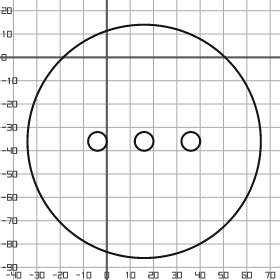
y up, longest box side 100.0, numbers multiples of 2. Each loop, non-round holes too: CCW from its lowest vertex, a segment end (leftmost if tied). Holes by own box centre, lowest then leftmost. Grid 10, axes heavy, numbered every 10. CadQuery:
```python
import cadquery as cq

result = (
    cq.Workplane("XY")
    .moveTo(16.0, -36.0)
    .circle(50.0)
    .moveTo(-4.0, -36.0)
    .circle(4.0)
    .moveTo(16.0, -36.0)
    .circle(4.0)
    .moveTo(36.0, -36.0)
    .circle(4.0)
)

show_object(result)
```